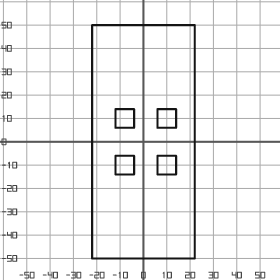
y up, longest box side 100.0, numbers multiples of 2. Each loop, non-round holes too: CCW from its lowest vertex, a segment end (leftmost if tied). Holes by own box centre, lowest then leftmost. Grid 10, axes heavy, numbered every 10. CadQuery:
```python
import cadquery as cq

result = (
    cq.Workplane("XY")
    .moveTo(-22.0, -50.0)
    .lineTo(22.0, -50.0)
    .lineTo(22.0, 50.0)
    .lineTo(-22.0, 50.0)
    .close()
    .moveTo(-12.0, -14.0)
    .lineTo(-4.0, -14.0)
    .lineTo(-4.0, -6.0)
    .lineTo(-12.0, -6.0)
    .close()
    .moveTo(6.0, -14.0)
    .lineTo(14.0, -14.0)
    .lineTo(14.0, -6.0)
    .lineTo(6.0, -6.0)
    .close()
    .moveTo(-12.0, 6.0)
    .lineTo(-4.0, 6.0)
    .lineTo(-4.0, 14.0)
    .lineTo(-12.0, 14.0)
    .close()
    .moveTo(6.0, 6.0)
    .lineTo(14.0, 6.0)
    .lineTo(14.0, 14.0)
    .lineTo(6.0, 14.0)
    .close()
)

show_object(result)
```